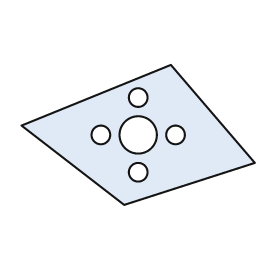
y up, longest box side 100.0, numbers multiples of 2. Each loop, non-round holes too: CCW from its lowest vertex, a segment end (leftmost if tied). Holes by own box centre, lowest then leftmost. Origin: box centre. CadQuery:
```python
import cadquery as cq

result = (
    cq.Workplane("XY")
    .moveTo(-6.0, -30.0)
    .lineTo(50.0, -12.0)
    .lineTo(14.0, 30.0)
    .lineTo(-50.0, 4.0)
    .close()
    .moveTo(0.0, -16.0)
    .circle(4.0)
    .moveTo(-16.0, 0.0)
    .circle(4.0)
    .moveTo(0.0, 0.0)
    .circle(8.0)
    .moveTo(16.0, 0.0)
    .circle(4.0)
    .moveTo(0.0, 16.0)
    .circle(4.0)
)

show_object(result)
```